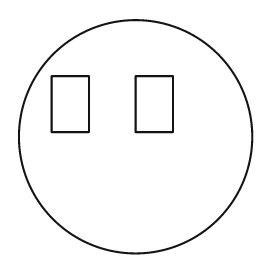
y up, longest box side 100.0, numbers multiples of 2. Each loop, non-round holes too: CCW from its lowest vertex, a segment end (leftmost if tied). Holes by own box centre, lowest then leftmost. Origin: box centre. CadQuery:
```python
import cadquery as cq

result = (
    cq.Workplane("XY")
    .moveTo(0.0, 0.0)
    .circle(50.0)
    .moveTo(-36.0, 2.0)
    .lineTo(-20.0, 2.0)
    .lineTo(-20.0, 26.0)
    .lineTo(-36.0, 26.0)
    .close()
    .moveTo(0.0, 2.0)
    .lineTo(16.0, 2.0)
    .lineTo(16.0, 26.0)
    .lineTo(0.0, 26.0)
    .close()
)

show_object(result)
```